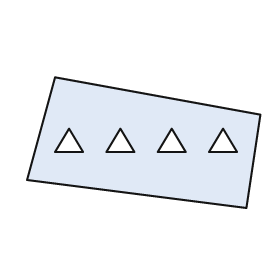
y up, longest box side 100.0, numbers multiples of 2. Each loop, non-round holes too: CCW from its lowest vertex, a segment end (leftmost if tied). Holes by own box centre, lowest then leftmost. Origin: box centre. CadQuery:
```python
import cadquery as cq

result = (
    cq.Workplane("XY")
    .moveTo(44.0, -28.0)
    .lineTo(50.0, 12.0)
    .lineTo(-38.0, 28.0)
    .lineTo(-50.0, -16.0)
    .close()
    .moveTo(-38.0, -4.0)
    .lineTo(-26.0, -4.0)
    .lineTo(-32.0, 6.0)
    .close()
    .moveTo(-16.0, -4.0)
    .lineTo(-4.0, -4.0)
    .lineTo(-10.0, 6.0)
    .close()
    .moveTo(6.0, -4.0)
    .lineTo(18.0, -4.0)
    .lineTo(12.0, 6.0)
    .close()
    .moveTo(28.0, -4.0)
    .lineTo(40.0, -4.0)
    .lineTo(34.0, 6.0)
    .close()
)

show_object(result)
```